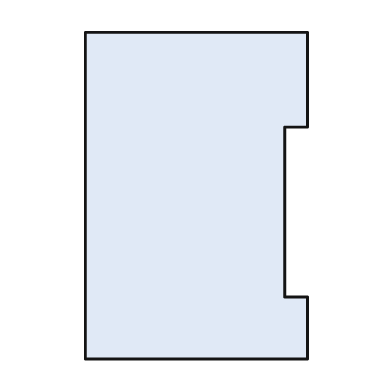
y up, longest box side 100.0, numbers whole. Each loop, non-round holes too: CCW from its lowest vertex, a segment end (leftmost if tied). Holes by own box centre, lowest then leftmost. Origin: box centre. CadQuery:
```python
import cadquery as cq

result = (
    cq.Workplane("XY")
    .moveTo(-34.0, -50.0)
    .lineTo(34.0, -50.0)
    .lineTo(34.0, -31.0)
    .lineTo(27.0, -31.0)
    .lineTo(27.0, 21.0)
    .lineTo(34.0, 21.0)
    .lineTo(34.0, 50.0)
    .lineTo(-34.0, 50.0)
    .close()
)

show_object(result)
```